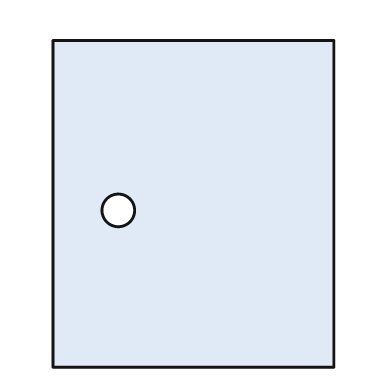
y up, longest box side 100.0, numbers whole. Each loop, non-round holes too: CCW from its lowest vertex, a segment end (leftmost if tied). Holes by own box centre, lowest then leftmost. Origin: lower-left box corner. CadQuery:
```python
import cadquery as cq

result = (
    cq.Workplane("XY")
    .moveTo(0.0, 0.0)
    .lineTo(86.0, 0.0)
    .lineTo(86.0, 100.0)
    .lineTo(0.0, 100.0)
    .close()
    .moveTo(20.0, 48.0)
    .circle(5.0)
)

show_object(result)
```